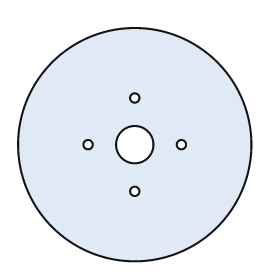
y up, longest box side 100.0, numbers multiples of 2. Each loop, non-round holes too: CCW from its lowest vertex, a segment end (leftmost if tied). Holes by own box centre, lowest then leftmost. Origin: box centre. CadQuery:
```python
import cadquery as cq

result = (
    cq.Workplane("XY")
    .moveTo(0.0, 0.0)
    .circle(50.0)
    .moveTo(0.0, -20.0)
    .circle(2.0)
    .moveTo(-20.0, 0.0)
    .circle(2.0)
    .moveTo(0.0, 0.0)
    .circle(8.0)
    .moveTo(20.0, 0.0)
    .circle(2.0)
    .moveTo(0.0, 20.0)
    .circle(2.0)
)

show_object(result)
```